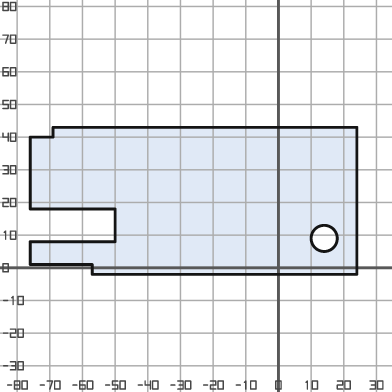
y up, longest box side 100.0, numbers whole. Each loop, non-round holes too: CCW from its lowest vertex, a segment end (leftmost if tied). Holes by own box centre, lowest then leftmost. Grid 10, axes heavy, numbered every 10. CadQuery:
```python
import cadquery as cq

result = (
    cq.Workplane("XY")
    .moveTo(-57.0, -2.0)
    .lineTo(24.0, -2.0)
    .lineTo(24.0, 43.0)
    .lineTo(-69.0, 43.0)
    .lineTo(-69.0, 40.0)
    .lineTo(-76.0, 40.0)
    .lineTo(-76.0, 18.0)
    .lineTo(-50.0, 18.0)
    .lineTo(-50.0, 8.0)
    .lineTo(-76.0, 8.0)
    .lineTo(-76.0, 1.0)
    .lineTo(-57.0, 1.0)
    .close()
    .moveTo(14.0, 9.0)
    .circle(4.0)
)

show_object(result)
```